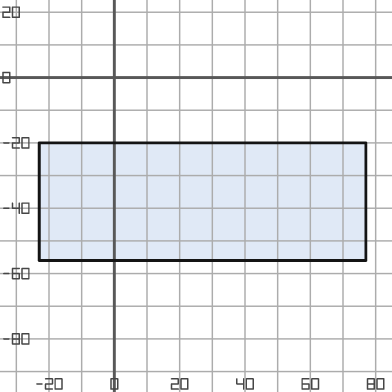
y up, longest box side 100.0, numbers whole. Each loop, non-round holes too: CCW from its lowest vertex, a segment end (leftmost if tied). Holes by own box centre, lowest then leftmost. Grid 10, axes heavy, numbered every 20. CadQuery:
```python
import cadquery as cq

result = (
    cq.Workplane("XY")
    .moveTo(-23.0, -56.0)
    .lineTo(77.0, -56.0)
    .lineTo(77.0, -20.0)
    .lineTo(-23.0, -20.0)
    .close()
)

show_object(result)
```